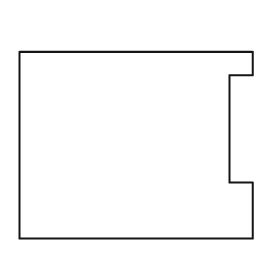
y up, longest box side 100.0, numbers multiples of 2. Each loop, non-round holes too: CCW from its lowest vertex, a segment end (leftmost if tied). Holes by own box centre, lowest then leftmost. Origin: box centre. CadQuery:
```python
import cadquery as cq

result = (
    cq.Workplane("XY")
    .moveTo(-50.0, -40.0)
    .lineTo(50.0, -40.0)
    .lineTo(50.0, -16.0)
    .lineTo(40.0, -16.0)
    .lineTo(40.0, 30.0)
    .lineTo(50.0, 30.0)
    .lineTo(50.0, 40.0)
    .lineTo(-50.0, 40.0)
    .close()
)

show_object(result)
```